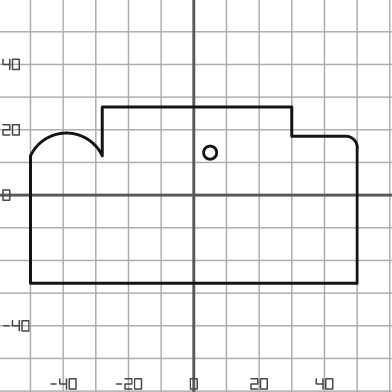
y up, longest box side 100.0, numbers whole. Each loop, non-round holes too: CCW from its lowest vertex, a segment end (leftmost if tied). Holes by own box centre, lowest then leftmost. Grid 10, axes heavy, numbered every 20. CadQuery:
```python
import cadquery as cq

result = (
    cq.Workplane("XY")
    .moveTo(-50.0, -27.0)
    .lineTo(50.0, -27.0)
    .lineTo(50.0, 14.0)
    .threePointArc((49.0, 17.0), (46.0, 18.0))
    .lineTo(30.0, 18.0)
    .lineTo(30.0, 27.0)
    .lineTo(-28.0, 27.0)
    .lineTo(-28.0, 12.0)
    .threePointArc((-39.0, 19.0), (-50.0, 12.0))
    .close()
    .moveTo(5.0, 13.0)
    .circle(2.0)
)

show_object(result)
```